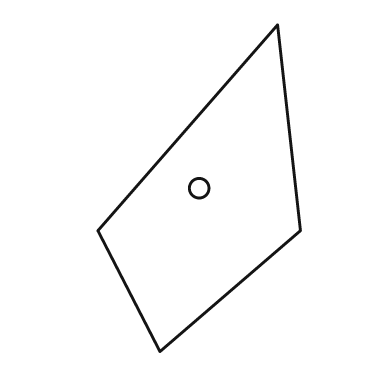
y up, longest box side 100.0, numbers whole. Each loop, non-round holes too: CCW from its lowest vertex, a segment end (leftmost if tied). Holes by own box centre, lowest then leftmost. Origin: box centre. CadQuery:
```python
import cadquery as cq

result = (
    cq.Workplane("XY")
    .moveTo(-12.0, -50.0)
    .lineTo(31.0, -13.0)
    .lineTo(24.0, 50.0)
    .lineTo(-31.0, -13.0)
    .close()
    .moveTo(0.0, 0.0)
    .circle(3.0)
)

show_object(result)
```